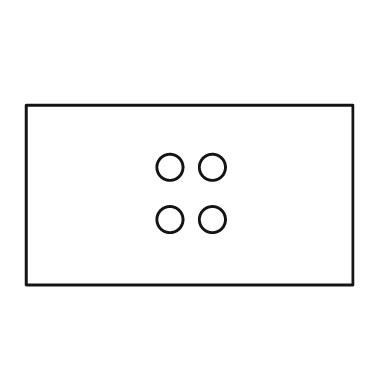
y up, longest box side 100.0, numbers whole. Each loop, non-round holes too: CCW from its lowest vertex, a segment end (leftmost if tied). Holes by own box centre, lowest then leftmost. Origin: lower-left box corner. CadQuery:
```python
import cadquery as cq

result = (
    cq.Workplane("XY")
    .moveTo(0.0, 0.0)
    .lineTo(100.0, 0.0)
    .lineTo(100.0, 55.0)
    .lineTo(0.0, 55.0)
    .close()
    .moveTo(44.0, 20.0)
    .circle(4.0)
    .moveTo(57.0, 20.0)
    .circle(4.0)
    .moveTo(44.0, 36.0)
    .circle(4.0)
    .moveTo(57.0, 36.0)
    .circle(4.0)
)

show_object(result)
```